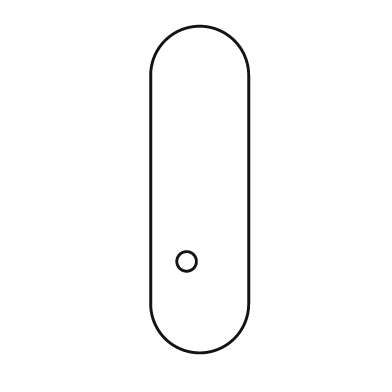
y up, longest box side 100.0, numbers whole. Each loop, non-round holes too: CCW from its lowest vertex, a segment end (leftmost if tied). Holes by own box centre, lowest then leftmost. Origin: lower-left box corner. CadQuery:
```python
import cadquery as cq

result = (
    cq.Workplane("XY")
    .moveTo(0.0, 15.0)
    .threePointArc((15.0, 0.0), (30.0, 15.0))
    .lineTo(30.0, 85.0)
    .threePointArc((15.0, 100.0), (0.0, 85.0))
    .close()
    .moveTo(11.0, 28.0)
    .circle(3.0)
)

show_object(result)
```